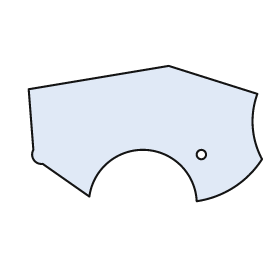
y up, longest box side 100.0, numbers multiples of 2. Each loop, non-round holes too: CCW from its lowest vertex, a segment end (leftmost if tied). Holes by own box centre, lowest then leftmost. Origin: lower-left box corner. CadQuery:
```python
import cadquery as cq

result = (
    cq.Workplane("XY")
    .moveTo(72.0, 0.0)
    .threePointArc((88.0, 6.0), (100.0, 18.0))
    .threePointArc((96.0, 32.0), (98.0, 46.0))
    .lineTo(60.0, 58.0)
    .lineTo(0.0, 48.0)
    .lineTo(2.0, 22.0)
    .threePointArc((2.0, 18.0), (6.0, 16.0))
    .lineTo(26.0, 2.0)
    .threePointArc((50.0, 22.0), (72.0, 0.0))
    .close()
    .moveTo(74.0, 20.0)
    .circle(2.0)
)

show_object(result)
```